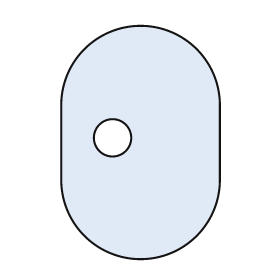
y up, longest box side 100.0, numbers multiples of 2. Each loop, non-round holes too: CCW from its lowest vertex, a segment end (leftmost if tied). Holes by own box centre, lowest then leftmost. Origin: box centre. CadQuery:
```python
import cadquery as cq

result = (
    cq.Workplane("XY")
    .moveTo(-34.0, -16.0)
    .threePointArc((0.0, -50.0), (34.0, -16.0))
    .lineTo(34.0, 16.0)
    .threePointArc((0.0, 50.0), (-34.0, 16.0))
    .close()
    .moveTo(-12.0, 2.0)
    .circle(8.0)
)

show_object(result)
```